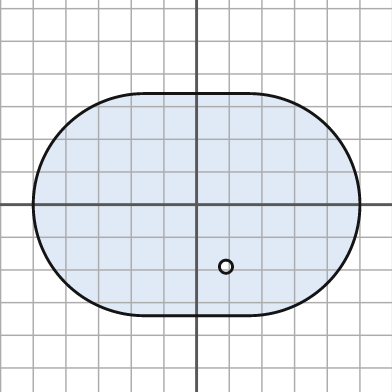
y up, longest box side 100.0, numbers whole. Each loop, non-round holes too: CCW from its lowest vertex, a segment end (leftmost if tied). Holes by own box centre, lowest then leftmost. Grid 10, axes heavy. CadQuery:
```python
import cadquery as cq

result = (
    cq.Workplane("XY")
    .moveTo(-16.0, -34.0)
    .lineTo(16.0, -34.0)
    .threePointArc((50.0, 0.0), (16.0, 34.0))
    .lineTo(-16.0, 34.0)
    .threePointArc((-50.0, 0.0), (-16.0, -34.0))
    .close()
    .moveTo(9.0, -19.0)
    .circle(2.0)
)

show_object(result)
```